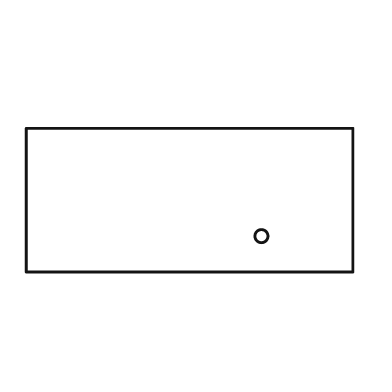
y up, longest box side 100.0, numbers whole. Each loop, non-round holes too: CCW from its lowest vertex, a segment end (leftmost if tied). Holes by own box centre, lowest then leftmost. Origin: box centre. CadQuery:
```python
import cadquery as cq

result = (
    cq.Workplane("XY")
    .moveTo(-50.0, -22.0)
    .lineTo(50.0, -22.0)
    .lineTo(50.0, 22.0)
    .lineTo(-50.0, 22.0)
    .close()
    .moveTo(22.0, -11.0)
    .circle(2.0)
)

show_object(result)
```